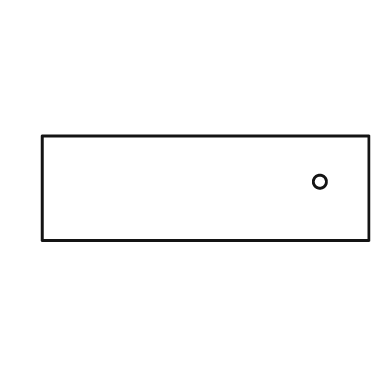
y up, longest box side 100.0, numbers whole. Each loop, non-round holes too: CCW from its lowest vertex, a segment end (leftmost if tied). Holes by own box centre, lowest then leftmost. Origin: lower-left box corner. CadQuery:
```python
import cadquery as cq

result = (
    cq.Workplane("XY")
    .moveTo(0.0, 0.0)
    .lineTo(100.0, 0.0)
    .lineTo(100.0, 32.0)
    .lineTo(0.0, 32.0)
    .close()
    .moveTo(85.0, 18.0)
    .circle(2.0)
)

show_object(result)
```